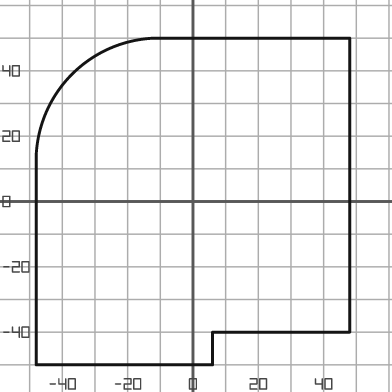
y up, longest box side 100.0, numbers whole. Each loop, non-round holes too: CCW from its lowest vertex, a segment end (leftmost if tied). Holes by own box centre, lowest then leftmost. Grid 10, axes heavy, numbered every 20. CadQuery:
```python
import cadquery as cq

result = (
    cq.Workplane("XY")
    .moveTo(-48.0, -50.0)
    .lineTo(6.0, -50.0)
    .lineTo(6.0, -40.0)
    .lineTo(48.0, -40.0)
    .lineTo(48.0, 50.0)
    .lineTo(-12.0, 50.0)
    .threePointArc((-37.0, 39.0), (-48.0, 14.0))
    .close()
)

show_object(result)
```